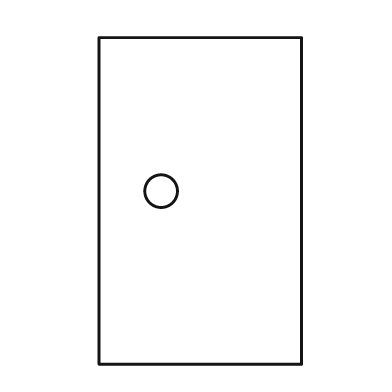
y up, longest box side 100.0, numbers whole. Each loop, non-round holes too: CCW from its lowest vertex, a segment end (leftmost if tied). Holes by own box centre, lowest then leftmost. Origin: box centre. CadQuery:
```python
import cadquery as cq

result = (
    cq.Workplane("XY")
    .moveTo(-31.0, -50.0)
    .lineTo(31.0, -50.0)
    .lineTo(31.0, 50.0)
    .lineTo(-31.0, 50.0)
    .close()
    .moveTo(-12.0, 3.0)
    .circle(5.0)
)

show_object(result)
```